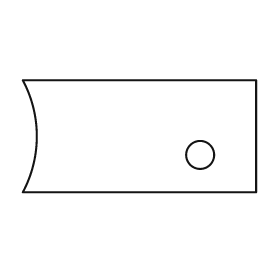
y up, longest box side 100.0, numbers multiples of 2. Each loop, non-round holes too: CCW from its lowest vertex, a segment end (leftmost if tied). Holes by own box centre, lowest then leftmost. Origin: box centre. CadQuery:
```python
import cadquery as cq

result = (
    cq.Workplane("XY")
    .moveTo(-50.0, -24.0)
    .lineTo(50.0, -24.0)
    .lineTo(50.0, 24.0)
    .lineTo(-50.0, 24.0)
    .threePointArc((-44.0, 0.0), (-50.0, -24.0))
    .close()
    .moveTo(26.0, -8.0)
    .circle(6.0)
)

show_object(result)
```